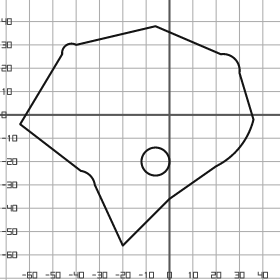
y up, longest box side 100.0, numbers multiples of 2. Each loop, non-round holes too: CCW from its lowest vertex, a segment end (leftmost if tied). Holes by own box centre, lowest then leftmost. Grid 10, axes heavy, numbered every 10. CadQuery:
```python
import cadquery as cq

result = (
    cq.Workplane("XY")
    .moveTo(-20.0, -56.0)
    .lineTo(0.0, -36.0)
    .lineTo(20.0, -22.0)
    .threePointArc((30.0, -14.0), (36.0, -2.0))
    .lineTo(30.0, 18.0)
    .threePointArc((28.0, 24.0), (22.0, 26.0))
    .lineTo(-6.0, 38.0)
    .lineTo(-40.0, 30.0)
    .threePointArc((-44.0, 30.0), (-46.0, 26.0))
    .lineTo(-64.0, -4.0)
    .lineTo(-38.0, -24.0)
    .threePointArc((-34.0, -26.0), (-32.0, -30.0))
    .close()
    .moveTo(-6.0, -20.0)
    .circle(6.0)
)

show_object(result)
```